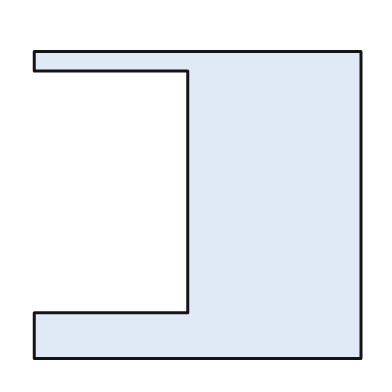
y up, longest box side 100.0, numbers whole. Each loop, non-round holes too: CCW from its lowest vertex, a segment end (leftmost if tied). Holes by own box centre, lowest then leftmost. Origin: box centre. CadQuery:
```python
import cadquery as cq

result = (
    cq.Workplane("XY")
    .moveTo(-50.0, -47.0)
    .lineTo(50.0, -47.0)
    .lineTo(50.0, 47.0)
    .lineTo(-50.0, 47.0)
    .lineTo(-50.0, 41.0)
    .lineTo(-3.0, 41.0)
    .lineTo(-3.0, -33.0)
    .lineTo(-50.0, -33.0)
    .close()
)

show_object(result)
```